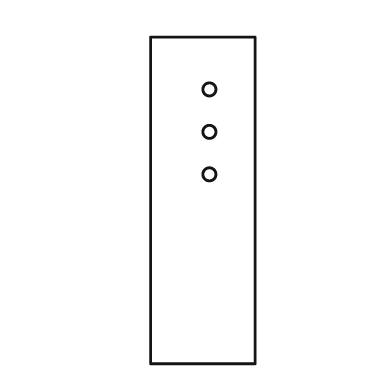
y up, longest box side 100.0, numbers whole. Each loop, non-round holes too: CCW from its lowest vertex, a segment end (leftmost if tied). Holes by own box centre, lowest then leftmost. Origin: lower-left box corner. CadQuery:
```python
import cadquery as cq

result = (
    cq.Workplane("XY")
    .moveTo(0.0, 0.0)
    .lineTo(32.0, 0.0)
    .lineTo(32.0, 100.0)
    .lineTo(0.0, 100.0)
    .close()
    .moveTo(18.0, 58.0)
    .circle(2.0)
    .moveTo(18.0, 71.0)
    .circle(2.0)
    .moveTo(18.0, 84.0)
    .circle(2.0)
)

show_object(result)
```